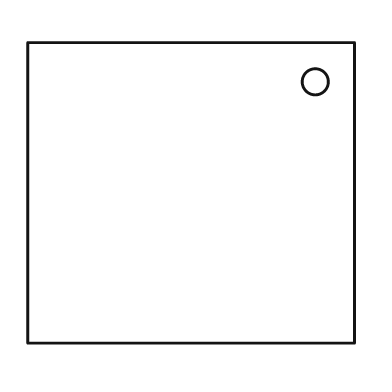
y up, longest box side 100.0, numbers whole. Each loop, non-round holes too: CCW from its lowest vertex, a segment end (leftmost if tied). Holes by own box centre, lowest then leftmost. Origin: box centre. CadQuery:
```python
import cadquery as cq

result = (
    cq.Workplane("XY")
    .moveTo(-50.0, -46.0)
    .lineTo(50.0, -46.0)
    .lineTo(50.0, 46.0)
    .lineTo(-50.0, 46.0)
    .close()
    .moveTo(38.0, 34.0)
    .circle(4.0)
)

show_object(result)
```